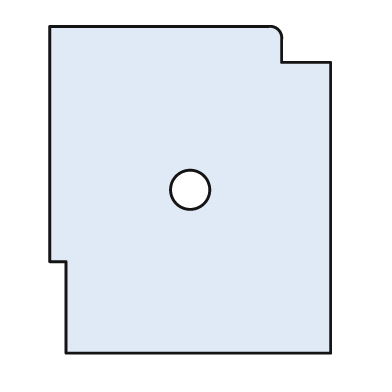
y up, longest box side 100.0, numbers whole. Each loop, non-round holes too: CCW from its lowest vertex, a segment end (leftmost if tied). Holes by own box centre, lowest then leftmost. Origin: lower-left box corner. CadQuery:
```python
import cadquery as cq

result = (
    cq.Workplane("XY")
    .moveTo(5.0, 0.0)
    .lineTo(86.0, 0.0)
    .lineTo(86.0, 89.0)
    .lineTo(71.0, 89.0)
    .lineTo(71.0, 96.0)
    .threePointArc((70.0, 99.0), (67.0, 100.0))
    .lineTo(0.0, 100.0)
    .lineTo(0.0, 28.0)
    .lineTo(5.0, 28.0)
    .close()
    .moveTo(43.0, 50.0)
    .circle(6.0)
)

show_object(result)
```